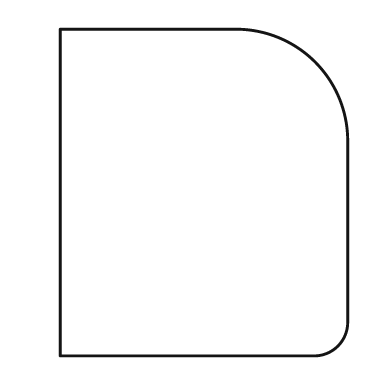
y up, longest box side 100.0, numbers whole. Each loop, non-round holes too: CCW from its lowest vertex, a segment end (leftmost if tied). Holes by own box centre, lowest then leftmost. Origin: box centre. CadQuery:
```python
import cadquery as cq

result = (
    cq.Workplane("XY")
    .moveTo(-44.0, -50.0)
    .lineTo(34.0, -50.0)
    .threePointArc((41.0, -47.0), (44.0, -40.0))
    .lineTo(44.0, 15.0)
    .threePointArc((34.0, 40.0), (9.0, 50.0))
    .lineTo(-44.0, 50.0)
    .close()
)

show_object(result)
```